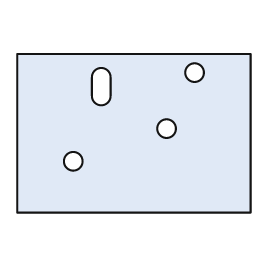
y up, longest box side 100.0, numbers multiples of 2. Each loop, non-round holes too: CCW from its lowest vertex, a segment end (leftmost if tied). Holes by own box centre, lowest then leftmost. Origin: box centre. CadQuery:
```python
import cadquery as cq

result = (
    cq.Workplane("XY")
    .moveTo(-50.0, -34.0)
    .lineTo(50.0, -34.0)
    .lineTo(50.0, 34.0)
    .lineTo(-50.0, 34.0)
    .close()
    .moveTo(-26.0, -12.0)
    .circle(4.0)
    .moveTo(14.0, 2.0)
    .circle(4.0)
    .moveTo(-18.0, 16.0)
    .threePointArc((-14.0, 12.0), (-10.0, 16.0))
    .lineTo(-10.0, 24.0)
    .threePointArc((-14.0, 28.0), (-18.0, 24.0))
    .close()
    .moveTo(26.0, 26.0)
    .circle(4.0)
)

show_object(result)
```